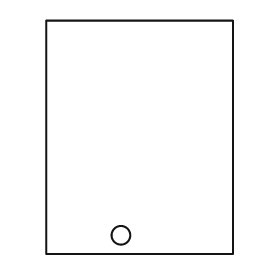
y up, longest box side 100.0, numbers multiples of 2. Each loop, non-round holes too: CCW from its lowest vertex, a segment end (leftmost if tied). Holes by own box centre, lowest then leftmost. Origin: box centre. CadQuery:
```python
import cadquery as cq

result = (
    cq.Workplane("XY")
    .moveTo(-40.0, -50.0)
    .lineTo(40.0, -50.0)
    .lineTo(40.0, 50.0)
    .lineTo(-40.0, 50.0)
    .close()
    .moveTo(-8.0, -42.0)
    .circle(4.0)
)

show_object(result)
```